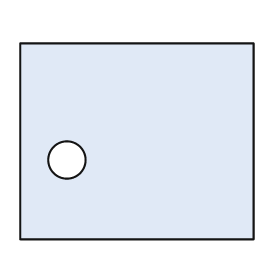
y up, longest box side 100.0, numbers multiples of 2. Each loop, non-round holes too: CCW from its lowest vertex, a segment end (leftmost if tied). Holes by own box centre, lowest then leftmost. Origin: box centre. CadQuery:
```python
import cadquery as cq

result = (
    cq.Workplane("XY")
    .moveTo(-50.0, -42.0)
    .lineTo(50.0, -42.0)
    .lineTo(50.0, 42.0)
    .lineTo(-50.0, 42.0)
    .close()
    .moveTo(-30.0, -8.0)
    .circle(8.0)
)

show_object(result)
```